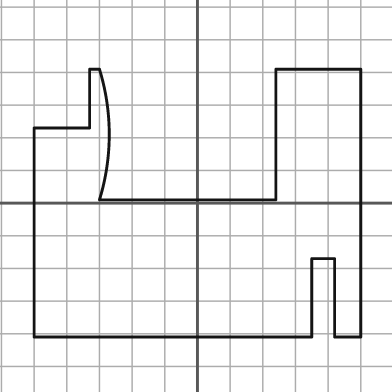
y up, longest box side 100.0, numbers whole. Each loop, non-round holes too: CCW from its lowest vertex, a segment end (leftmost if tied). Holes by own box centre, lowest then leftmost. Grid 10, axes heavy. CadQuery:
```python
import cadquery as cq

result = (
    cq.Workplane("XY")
    .moveTo(-50.0, -41.0)
    .lineTo(35.0, -41.0)
    .lineTo(35.0, -17.0)
    .lineTo(42.0, -17.0)
    .lineTo(42.0, -41.0)
    .lineTo(50.0, -41.0)
    .lineTo(50.0, 41.0)
    .lineTo(24.0, 41.0)
    .lineTo(24.0, 1.0)
    .lineTo(-30.0, 1.0)
    .threePointArc((-27.0, 21.0), (-30.0, 41.0))
    .lineTo(-33.0, 41.0)
    .lineTo(-33.0, 23.0)
    .lineTo(-50.0, 23.0)
    .close()
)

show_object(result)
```